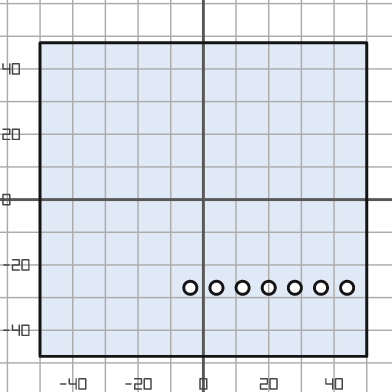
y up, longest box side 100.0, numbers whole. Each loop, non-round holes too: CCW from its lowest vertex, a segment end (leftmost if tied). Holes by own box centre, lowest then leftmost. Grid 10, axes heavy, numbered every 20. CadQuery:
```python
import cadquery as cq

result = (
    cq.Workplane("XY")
    .moveTo(-50.0, -48.0)
    .lineTo(50.0, -48.0)
    .lineTo(50.0, 48.0)
    .lineTo(-50.0, 48.0)
    .close()
    .moveTo(-4.0, -27.0)
    .circle(2.0)
    .moveTo(4.0, -27.0)
    .circle(2.0)
    .moveTo(12.0, -27.0)
    .circle(2.0)
    .moveTo(20.0, -27.0)
    .circle(2.0)
    .moveTo(28.0, -27.0)
    .circle(2.0)
    .moveTo(36.0, -27.0)
    .circle(2.0)
    .moveTo(44.0, -27.0)
    .circle(2.0)
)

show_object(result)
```